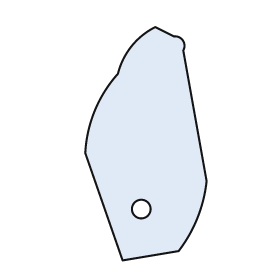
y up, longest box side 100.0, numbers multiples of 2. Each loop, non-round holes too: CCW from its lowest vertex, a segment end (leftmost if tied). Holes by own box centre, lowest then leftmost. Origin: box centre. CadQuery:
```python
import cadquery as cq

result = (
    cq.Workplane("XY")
    .moveTo(-10.0, -50.0)
    .lineTo(14.0, -46.0)
    .threePointArc((22.0, -32.0), (26.0, -16.0))
    .lineTo(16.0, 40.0)
    .threePointArc((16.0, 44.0), (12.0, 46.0))
    .lineTo(4.0, 50.0)
    .threePointArc((-6.0, 42.0), (-12.0, 30.0))
    .threePointArc((-22.0, 14.0), (-26.0, -4.0))
    .close()
    .moveTo(-2.0, -28.0)
    .circle(4.0)
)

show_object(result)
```